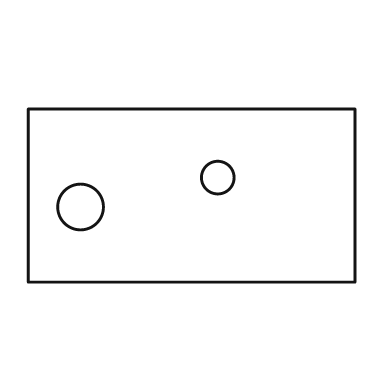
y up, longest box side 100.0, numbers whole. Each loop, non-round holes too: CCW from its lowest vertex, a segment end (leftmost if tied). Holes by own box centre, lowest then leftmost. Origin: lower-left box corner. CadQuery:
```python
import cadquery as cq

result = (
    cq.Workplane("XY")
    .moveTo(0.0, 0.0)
    .lineTo(100.0, 0.0)
    .lineTo(100.0, 53.0)
    .lineTo(0.0, 53.0)
    .close()
    .moveTo(16.0, 23.0)
    .circle(7.0)
    .moveTo(58.0, 32.0)
    .circle(5.0)
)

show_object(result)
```